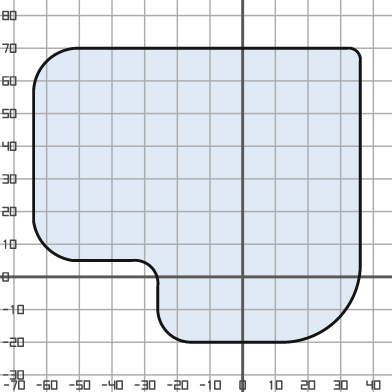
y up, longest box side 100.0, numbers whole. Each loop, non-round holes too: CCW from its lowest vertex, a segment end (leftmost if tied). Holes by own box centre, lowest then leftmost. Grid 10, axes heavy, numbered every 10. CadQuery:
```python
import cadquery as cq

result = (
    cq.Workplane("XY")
    .moveTo(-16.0, -20.0)
    .lineTo(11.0, -20.0)
    .threePointArc((29.0, -13.0), (36.0, 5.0))
    .lineTo(36.0, 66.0)
    .threePointArc((35.0, 69.0), (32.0, 70.0))
    .lineTo(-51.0, 70.0)
    .threePointArc((-60.0, 66.0), (-64.0, 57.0))
    .lineTo(-64.0, 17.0)
    .threePointArc((-60.0, 9.0), (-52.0, 5.0))
    .lineTo(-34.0, 5.0)
    .threePointArc((-28.0, 3.0), (-26.0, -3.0))
    .lineTo(-26.0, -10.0)
    .threePointArc((-23.0, -17.0), (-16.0, -20.0))
    .close()
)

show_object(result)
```